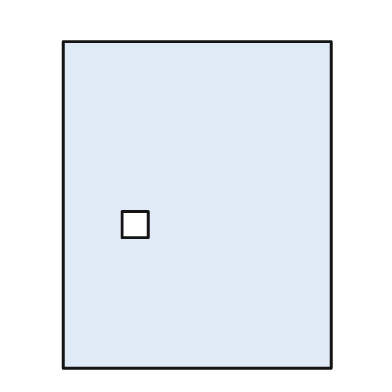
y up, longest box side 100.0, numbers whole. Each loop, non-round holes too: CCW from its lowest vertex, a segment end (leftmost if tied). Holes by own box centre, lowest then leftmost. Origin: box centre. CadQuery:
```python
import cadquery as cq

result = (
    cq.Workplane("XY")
    .moveTo(-41.0, -50.0)
    .lineTo(41.0, -50.0)
    .lineTo(41.0, 50.0)
    .lineTo(-41.0, 50.0)
    .close()
    .moveTo(-23.0, -10.0)
    .lineTo(-15.0, -10.0)
    .lineTo(-15.0, -2.0)
    .lineTo(-23.0, -2.0)
    .close()
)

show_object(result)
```